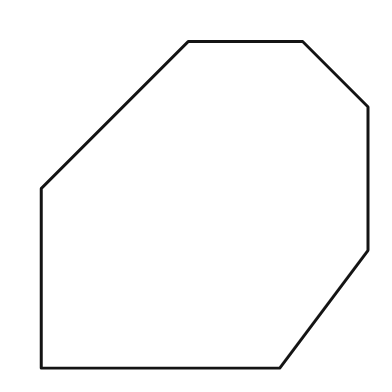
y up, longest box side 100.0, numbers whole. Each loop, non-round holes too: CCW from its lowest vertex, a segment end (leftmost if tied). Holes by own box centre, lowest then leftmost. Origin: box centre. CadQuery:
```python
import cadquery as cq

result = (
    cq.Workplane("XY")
    .moveTo(-50.0, -50.0)
    .lineTo(23.0, -50.0)
    .lineTo(50.0, -14.0)
    .lineTo(50.0, 30.0)
    .lineTo(30.0, 50.0)
    .lineTo(-5.0, 50.0)
    .lineTo(-50.0, 5.0)
    .close()
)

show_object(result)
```